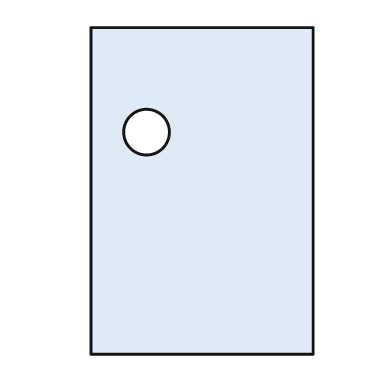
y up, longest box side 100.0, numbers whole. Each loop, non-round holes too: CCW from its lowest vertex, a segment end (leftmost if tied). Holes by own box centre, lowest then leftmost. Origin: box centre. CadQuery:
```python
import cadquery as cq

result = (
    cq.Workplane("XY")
    .moveTo(-34.0, -50.0)
    .lineTo(34.0, -50.0)
    .lineTo(34.0, 50.0)
    .lineTo(-34.0, 50.0)
    .close()
    .moveTo(-17.0, 18.0)
    .circle(7.0)
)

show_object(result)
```